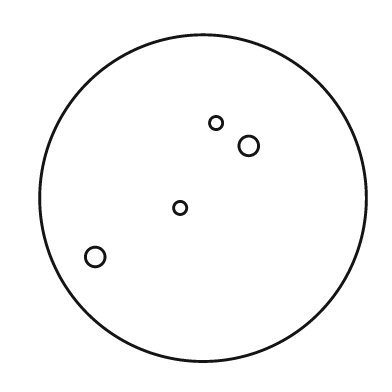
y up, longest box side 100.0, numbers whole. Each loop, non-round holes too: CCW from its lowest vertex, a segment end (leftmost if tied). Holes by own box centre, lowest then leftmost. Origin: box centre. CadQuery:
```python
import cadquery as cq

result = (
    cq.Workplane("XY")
    .moveTo(0.0, 0.0)
    .circle(50.0)
    .moveTo(-33.0, -18.0)
    .circle(3.0)
    .moveTo(-7.0, -3.0)
    .circle(2.0)
    .moveTo(14.0, 16.0)
    .circle(3.0)
    .moveTo(4.0, 23.0)
    .circle(2.0)
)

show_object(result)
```